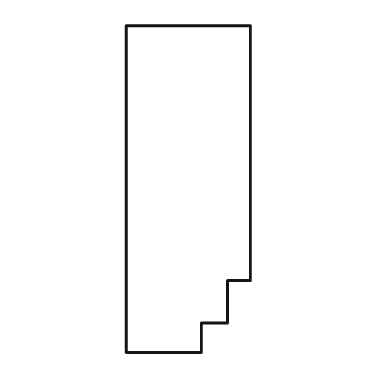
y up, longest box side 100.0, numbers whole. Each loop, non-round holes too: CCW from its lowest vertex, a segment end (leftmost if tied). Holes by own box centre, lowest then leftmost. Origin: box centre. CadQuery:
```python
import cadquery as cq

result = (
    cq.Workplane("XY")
    .moveTo(-19.0, -50.0)
    .lineTo(4.0, -50.0)
    .lineTo(4.0, -41.0)
    .lineTo(12.0, -41.0)
    .lineTo(12.0, -28.0)
    .lineTo(19.0, -28.0)
    .lineTo(19.0, 50.0)
    .lineTo(-19.0, 50.0)
    .close()
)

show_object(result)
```